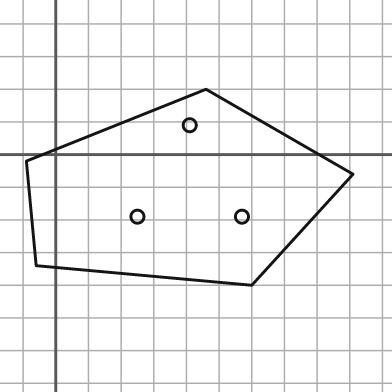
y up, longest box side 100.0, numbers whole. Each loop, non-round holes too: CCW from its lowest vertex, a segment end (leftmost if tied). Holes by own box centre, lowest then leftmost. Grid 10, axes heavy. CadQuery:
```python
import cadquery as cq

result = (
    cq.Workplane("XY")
    .moveTo(60.0, -40.0)
    .lineTo(91.0, -6.0)
    .lineTo(46.0, 20.0)
    .lineTo(-9.0, -2.0)
    .lineTo(-6.0, -34.0)
    .close()
    .moveTo(25.0, -19.0)
    .circle(2.0)
    .moveTo(57.0, -19.0)
    .circle(2.0)
    .moveTo(41.0, 9.0)
    .circle(2.0)
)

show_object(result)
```